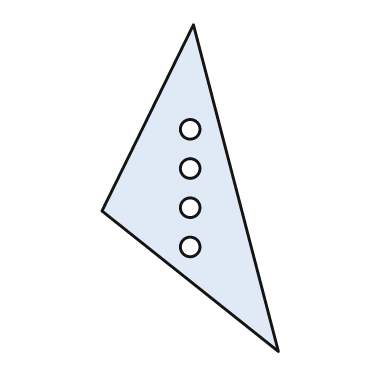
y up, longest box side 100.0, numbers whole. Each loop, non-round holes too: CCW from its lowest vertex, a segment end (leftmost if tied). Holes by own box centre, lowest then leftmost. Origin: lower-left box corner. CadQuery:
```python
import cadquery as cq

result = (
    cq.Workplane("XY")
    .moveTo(54.0, 0.0)
    .lineTo(28.0, 100.0)
    .lineTo(0.0, 43.0)
    .close()
    .moveTo(27.0, 32.0)
    .circle(3.0)
    .moveTo(27.0, 44.0)
    .circle(3.0)
    .moveTo(27.0, 56.0)
    .circle(3.0)
    .moveTo(27.0, 68.0)
    .circle(3.0)
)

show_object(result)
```